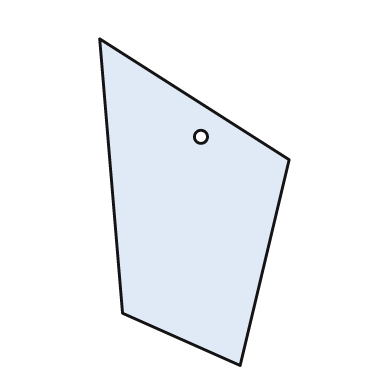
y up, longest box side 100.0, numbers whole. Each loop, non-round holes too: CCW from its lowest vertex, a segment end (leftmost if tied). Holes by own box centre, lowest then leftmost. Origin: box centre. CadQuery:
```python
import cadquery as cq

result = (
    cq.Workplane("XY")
    .moveTo(14.0, -50.0)
    .lineTo(29.0, 13.0)
    .lineTo(-29.0, 50.0)
    .lineTo(-22.0, -34.0)
    .close()
    .moveTo(2.0, 20.0)
    .circle(2.0)
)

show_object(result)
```